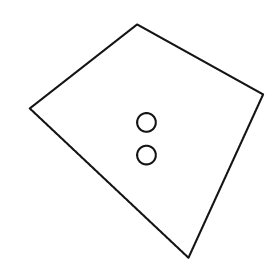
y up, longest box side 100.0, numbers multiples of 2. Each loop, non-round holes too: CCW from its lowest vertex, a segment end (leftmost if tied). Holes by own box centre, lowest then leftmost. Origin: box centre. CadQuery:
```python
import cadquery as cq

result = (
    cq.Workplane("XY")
    .moveTo(18.0, -50.0)
    .lineTo(50.0, 20.0)
    .lineTo(-4.0, 50.0)
    .lineTo(-50.0, 14.0)
    .close()
    .moveTo(0.0, -6.0)
    .circle(4.0)
    .moveTo(0.0, 8.0)
    .circle(4.0)
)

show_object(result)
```